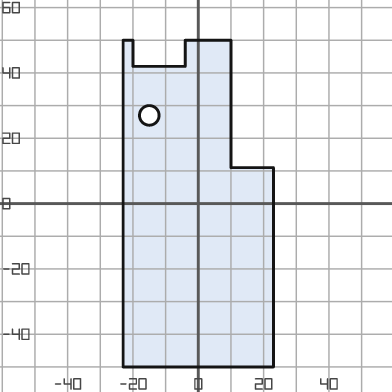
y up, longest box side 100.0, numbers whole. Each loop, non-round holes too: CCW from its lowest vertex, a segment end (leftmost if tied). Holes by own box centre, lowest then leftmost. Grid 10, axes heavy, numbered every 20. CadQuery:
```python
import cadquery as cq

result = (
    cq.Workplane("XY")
    .moveTo(-23.0, -50.0)
    .lineTo(23.0, -50.0)
    .lineTo(23.0, 11.0)
    .lineTo(10.0, 11.0)
    .lineTo(10.0, 50.0)
    .lineTo(-4.0, 50.0)
    .lineTo(-4.0, 42.0)
    .lineTo(-20.0, 42.0)
    .lineTo(-20.0, 50.0)
    .lineTo(-23.0, 50.0)
    .close()
    .moveTo(-15.0, 27.0)
    .circle(3.0)
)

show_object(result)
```